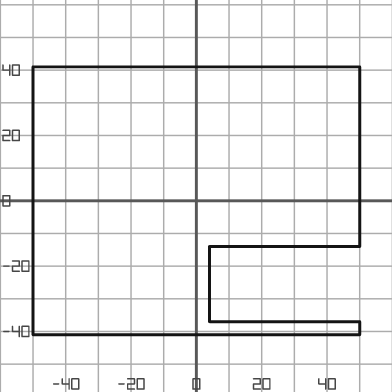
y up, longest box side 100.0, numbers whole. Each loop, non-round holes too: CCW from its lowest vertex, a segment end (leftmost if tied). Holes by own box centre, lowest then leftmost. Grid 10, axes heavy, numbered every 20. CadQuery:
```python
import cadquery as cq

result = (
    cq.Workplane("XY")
    .moveTo(-50.0, -41.0)
    .lineTo(50.0, -41.0)
    .lineTo(50.0, -37.0)
    .lineTo(4.0, -37.0)
    .lineTo(4.0, -14.0)
    .lineTo(50.0, -14.0)
    .lineTo(50.0, 41.0)
    .lineTo(-50.0, 41.0)
    .close()
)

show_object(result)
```